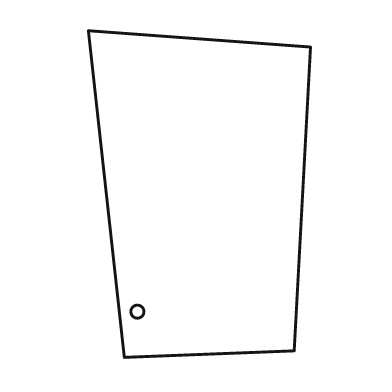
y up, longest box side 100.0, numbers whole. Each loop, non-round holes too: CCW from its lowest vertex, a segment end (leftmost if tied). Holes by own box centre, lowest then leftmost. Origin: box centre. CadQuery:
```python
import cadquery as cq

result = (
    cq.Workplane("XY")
    .moveTo(-23.0, -50.0)
    .lineTo(29.0, -48.0)
    .lineTo(34.0, 45.0)
    .lineTo(-34.0, 50.0)
    .close()
    .moveTo(-19.0, -36.0)
    .circle(2.0)
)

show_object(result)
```